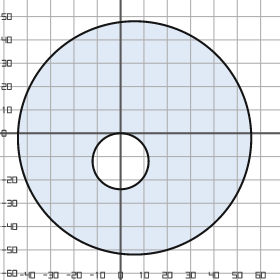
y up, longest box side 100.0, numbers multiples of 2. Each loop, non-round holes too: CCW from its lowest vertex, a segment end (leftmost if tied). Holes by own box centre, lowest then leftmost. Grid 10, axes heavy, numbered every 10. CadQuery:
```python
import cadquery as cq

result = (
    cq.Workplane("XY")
    .moveTo(6.0, -2.0)
    .circle(50.0)
    .moveTo(0.0, -12.0)
    .circle(12.0)
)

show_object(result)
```